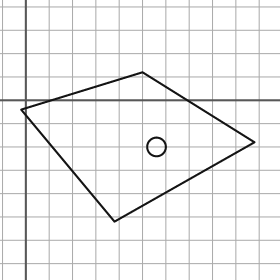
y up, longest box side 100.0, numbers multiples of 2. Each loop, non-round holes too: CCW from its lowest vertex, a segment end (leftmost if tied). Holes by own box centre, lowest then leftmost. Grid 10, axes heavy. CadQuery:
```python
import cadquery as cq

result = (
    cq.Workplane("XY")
    .moveTo(38.0, -52.0)
    .lineTo(98.0, -18.0)
    .lineTo(50.0, 12.0)
    .lineTo(-2.0, -4.0)
    .close()
    .moveTo(56.0, -20.0)
    .circle(4.0)
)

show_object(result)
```